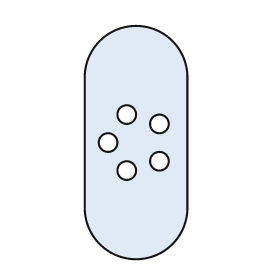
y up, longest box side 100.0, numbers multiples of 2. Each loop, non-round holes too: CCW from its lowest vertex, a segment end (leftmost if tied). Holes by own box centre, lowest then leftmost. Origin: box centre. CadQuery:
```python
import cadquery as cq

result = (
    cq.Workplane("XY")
    .moveTo(-22.0, -28.0)
    .threePointArc((0.0, -50.0), (22.0, -28.0))
    .lineTo(22.0, 28.0)
    .threePointArc((0.0, 50.0), (-22.0, 28.0))
    .close()
    .moveTo(-4.0, -12.0)
    .circle(4.0)
    .moveTo(10.0, -8.0)
    .circle(4.0)
    .moveTo(-12.0, 0.0)
    .circle(4.0)
    .moveTo(10.0, 8.0)
    .circle(4.0)
    .moveTo(-4.0, 12.0)
    .circle(4.0)
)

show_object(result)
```